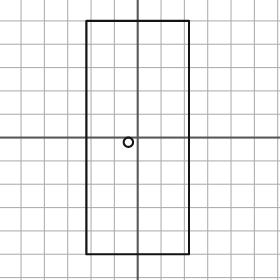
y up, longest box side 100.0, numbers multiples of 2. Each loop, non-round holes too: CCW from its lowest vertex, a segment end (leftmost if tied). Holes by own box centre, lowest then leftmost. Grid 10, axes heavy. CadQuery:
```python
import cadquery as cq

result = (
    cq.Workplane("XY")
    .moveTo(-22.0, -50.0)
    .lineTo(22.0, -50.0)
    .lineTo(22.0, 50.0)
    .lineTo(-22.0, 50.0)
    .close()
    .moveTo(-4.0, -2.0)
    .circle(2.0)
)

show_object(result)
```